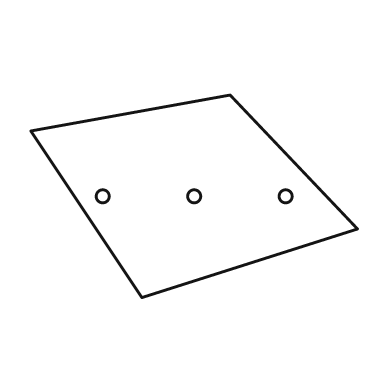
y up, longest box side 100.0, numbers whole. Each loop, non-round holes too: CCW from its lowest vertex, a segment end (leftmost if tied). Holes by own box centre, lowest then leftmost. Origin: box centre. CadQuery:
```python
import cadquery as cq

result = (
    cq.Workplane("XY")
    .moveTo(-16.0, -31.0)
    .lineTo(50.0, -10.0)
    .lineTo(11.0, 31.0)
    .lineTo(-50.0, 20.0)
    .close()
    .moveTo(-28.0, 0.0)
    .circle(2.0)
    .moveTo(0.0, 0.0)
    .circle(2.0)
    .moveTo(28.0, 0.0)
    .circle(2.0)
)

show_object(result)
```